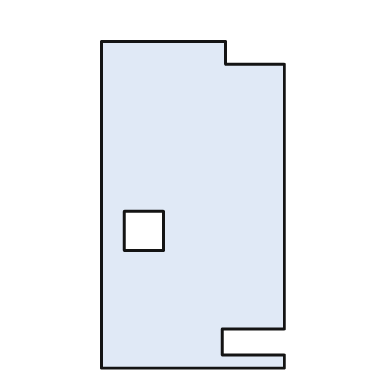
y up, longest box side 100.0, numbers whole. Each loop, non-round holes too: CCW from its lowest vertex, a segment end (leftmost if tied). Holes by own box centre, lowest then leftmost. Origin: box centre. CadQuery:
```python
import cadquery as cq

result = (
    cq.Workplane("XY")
    .moveTo(-28.0, -50.0)
    .lineTo(28.0, -50.0)
    .lineTo(28.0, -46.0)
    .lineTo(9.0, -46.0)
    .lineTo(9.0, -38.0)
    .lineTo(28.0, -38.0)
    .lineTo(28.0, 43.0)
    .lineTo(10.0, 43.0)
    .lineTo(10.0, 50.0)
    .lineTo(-28.0, 50.0)
    .close()
    .moveTo(-21.0, -14.0)
    .lineTo(-9.0, -14.0)
    .lineTo(-9.0, -2.0)
    .lineTo(-21.0, -2.0)
    .close()
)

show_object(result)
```